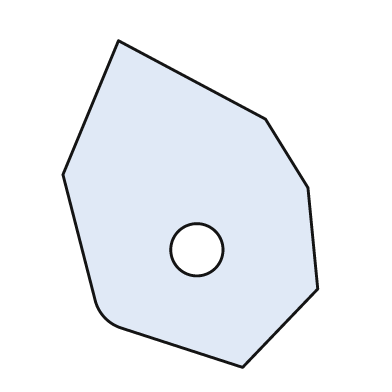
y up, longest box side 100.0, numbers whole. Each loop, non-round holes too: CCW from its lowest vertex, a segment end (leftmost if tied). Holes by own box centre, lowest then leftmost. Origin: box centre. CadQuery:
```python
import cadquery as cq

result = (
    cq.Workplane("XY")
    .moveTo(16.0, -50.0)
    .lineTo(39.0, -26.0)
    .lineTo(36.0, 5.0)
    .lineTo(23.0, 26.0)
    .lineTo(-22.0, 50.0)
    .lineTo(-39.0, 9.0)
    .lineTo(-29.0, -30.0)
    .threePointArc((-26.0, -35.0), (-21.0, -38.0))
    .close()
    .moveTo(2.0, -14.0)
    .circle(8.0)
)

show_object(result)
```